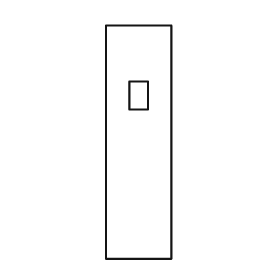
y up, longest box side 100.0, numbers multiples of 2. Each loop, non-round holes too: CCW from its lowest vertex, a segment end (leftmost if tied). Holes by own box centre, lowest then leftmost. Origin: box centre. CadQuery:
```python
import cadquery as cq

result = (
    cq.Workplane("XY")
    .moveTo(-14.0, -50.0)
    .lineTo(14.0, -50.0)
    .lineTo(14.0, 50.0)
    .lineTo(-14.0, 50.0)
    .close()
    .moveTo(-4.0, 14.0)
    .lineTo(4.0, 14.0)
    .lineTo(4.0, 26.0)
    .lineTo(-4.0, 26.0)
    .close()
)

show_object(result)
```